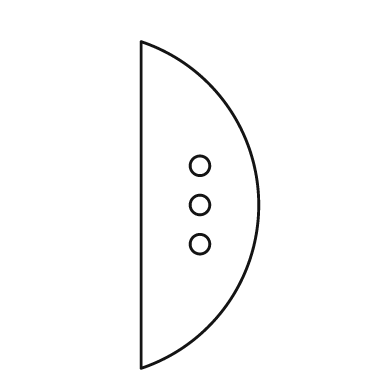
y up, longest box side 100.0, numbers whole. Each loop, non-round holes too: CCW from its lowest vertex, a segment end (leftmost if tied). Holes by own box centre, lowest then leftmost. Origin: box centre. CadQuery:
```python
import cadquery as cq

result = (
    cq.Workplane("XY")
    .moveTo(-18.0, -50.0)
    .threePointArc((18.0, 0.0), (-18.0, 50.0))
    .close()
    .moveTo(0.0, -12.0)
    .circle(3.0)
    .moveTo(0.0, 0.0)
    .circle(3.0)
    .moveTo(0.0, 12.0)
    .circle(3.0)
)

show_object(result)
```